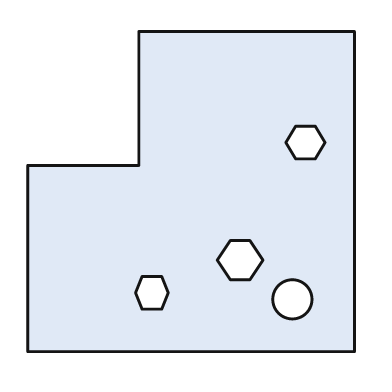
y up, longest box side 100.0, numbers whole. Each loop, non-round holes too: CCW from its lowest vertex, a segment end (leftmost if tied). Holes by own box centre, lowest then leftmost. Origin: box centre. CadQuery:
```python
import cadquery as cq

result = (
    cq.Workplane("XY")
    .moveTo(-50.0, -49.0)
    .lineTo(50.0, -49.0)
    .lineTo(50.0, 49.0)
    .lineTo(-16.0, 49.0)
    .lineTo(-16.0, 8.0)
    .lineTo(-50.0, 8.0)
    .close()
    .moveTo(31.0, -33.0)
    .circle(6.0)
    .moveTo(-15.0, -36.0)
    .lineTo(-9.0, -36.0)
    .lineTo(-7.0, -31.0)
    .lineTo(-9.0, -26.0)
    .lineTo(-15.0, -26.0)
    .lineTo(-17.0, -31.0)
    .close()
    .moveTo(12.0, -27.0)
    .lineTo(18.0, -27.0)
    .lineTo(22.0, -21.0)
    .lineTo(18.0, -15.0)
    .lineTo(12.0, -15.0)
    .lineTo(8.0, -21.0)
    .close()
    .moveTo(32.0, 10.0)
    .lineTo(38.0, 10.0)
    .lineTo(41.0, 15.0)
    .lineTo(38.0, 20.0)
    .lineTo(32.0, 20.0)
    .lineTo(29.0, 15.0)
    .close()
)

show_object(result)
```